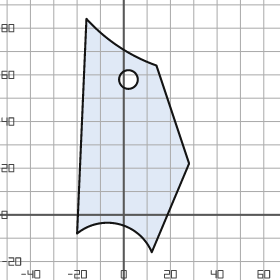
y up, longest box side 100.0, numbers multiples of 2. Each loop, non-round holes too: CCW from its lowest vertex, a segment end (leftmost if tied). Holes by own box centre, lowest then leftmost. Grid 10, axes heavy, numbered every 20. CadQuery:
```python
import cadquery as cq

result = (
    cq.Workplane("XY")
    .moveTo(12.0, -16.0)
    .lineTo(28.0, 22.0)
    .lineTo(14.0, 64.0)
    .threePointArc((-2.0, 72.0), (-16.0, 84.0))
    .lineTo(-20.0, -8.0)
    .threePointArc((-2.0, -4.0), (12.0, -16.0))
    .close()
    .moveTo(2.0, 58.0)
    .circle(4.0)
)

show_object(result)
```